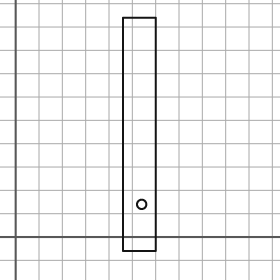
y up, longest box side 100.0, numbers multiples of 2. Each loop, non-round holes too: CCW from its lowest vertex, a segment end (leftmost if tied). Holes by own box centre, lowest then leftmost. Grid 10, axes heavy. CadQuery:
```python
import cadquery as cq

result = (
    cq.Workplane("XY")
    .moveTo(46.0, -6.0)
    .lineTo(60.0, -6.0)
    .lineTo(60.0, 94.0)
    .lineTo(46.0, 94.0)
    .close()
    .moveTo(54.0, 14.0)
    .circle(2.0)
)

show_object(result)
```